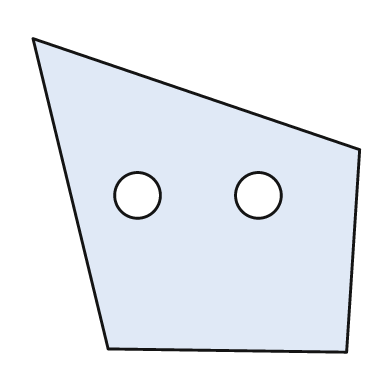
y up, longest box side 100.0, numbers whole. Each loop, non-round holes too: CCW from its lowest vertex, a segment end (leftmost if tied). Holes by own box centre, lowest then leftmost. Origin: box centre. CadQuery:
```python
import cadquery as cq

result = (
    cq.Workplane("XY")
    .moveTo(46.0, -48.0)
    .lineTo(50.0, 14.0)
    .lineTo(-50.0, 48.0)
    .lineTo(-27.0, -47.0)
    .close()
    .moveTo(-18.0, 0.0)
    .circle(7.0)
    .moveTo(19.0, 0.0)
    .circle(7.0)
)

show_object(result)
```